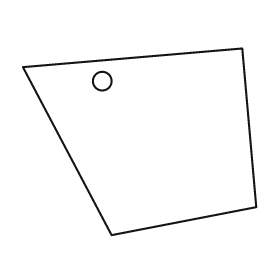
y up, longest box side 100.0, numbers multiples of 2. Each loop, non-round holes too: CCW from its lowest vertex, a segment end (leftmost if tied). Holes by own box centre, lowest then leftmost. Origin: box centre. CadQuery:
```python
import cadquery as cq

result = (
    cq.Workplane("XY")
    .moveTo(-12.0, -40.0)
    .lineTo(50.0, -28.0)
    .lineTo(44.0, 40.0)
    .lineTo(-50.0, 32.0)
    .close()
    .moveTo(-16.0, 26.0)
    .circle(4.0)
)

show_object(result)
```